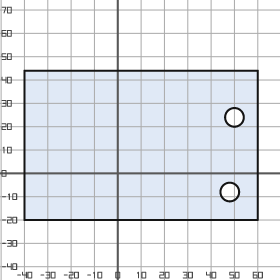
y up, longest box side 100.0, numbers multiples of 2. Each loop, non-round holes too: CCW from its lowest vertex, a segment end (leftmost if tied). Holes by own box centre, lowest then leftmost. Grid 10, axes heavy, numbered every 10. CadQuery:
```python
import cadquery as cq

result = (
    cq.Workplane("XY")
    .moveTo(-40.0, -20.0)
    .lineTo(60.0, -20.0)
    .lineTo(60.0, 44.0)
    .lineTo(-40.0, 44.0)
    .close()
    .moveTo(48.0, -8.0)
    .circle(4.0)
    .moveTo(50.0, 24.0)
    .circle(4.0)
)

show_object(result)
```